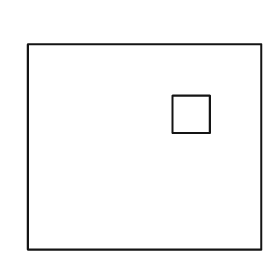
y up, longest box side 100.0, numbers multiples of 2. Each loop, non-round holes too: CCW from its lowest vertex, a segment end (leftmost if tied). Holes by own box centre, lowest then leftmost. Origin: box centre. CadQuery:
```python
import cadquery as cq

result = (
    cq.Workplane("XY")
    .moveTo(-50.0, -44.0)
    .lineTo(50.0, -44.0)
    .lineTo(50.0, 44.0)
    .lineTo(-50.0, 44.0)
    .close()
    .moveTo(12.0, 6.0)
    .lineTo(28.0, 6.0)
    .lineTo(28.0, 22.0)
    .lineTo(12.0, 22.0)
    .close()
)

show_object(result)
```